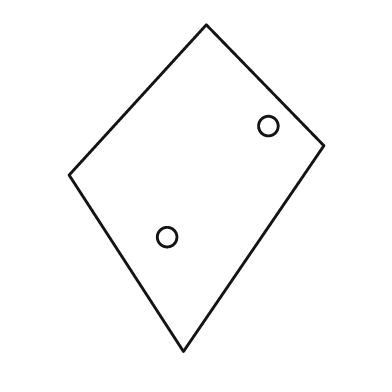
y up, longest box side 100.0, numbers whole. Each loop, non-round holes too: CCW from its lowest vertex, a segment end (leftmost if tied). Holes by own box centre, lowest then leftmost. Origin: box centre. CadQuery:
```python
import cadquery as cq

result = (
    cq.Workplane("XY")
    .moveTo(-4.0, -50.0)
    .lineTo(39.0, 13.0)
    .lineTo(3.0, 50.0)
    .lineTo(-39.0, 4.0)
    .close()
    .moveTo(-9.0, -15.0)
    .circle(3.0)
    .moveTo(22.0, 19.0)
    .circle(3.0)
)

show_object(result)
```